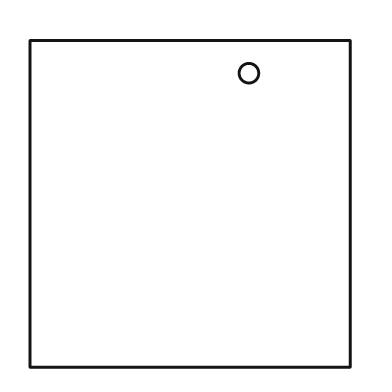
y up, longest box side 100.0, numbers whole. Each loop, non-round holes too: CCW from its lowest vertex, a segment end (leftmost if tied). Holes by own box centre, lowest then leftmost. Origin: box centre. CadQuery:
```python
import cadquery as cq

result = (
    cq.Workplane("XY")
    .moveTo(-49.0, -50.0)
    .lineTo(49.0, -50.0)
    .lineTo(49.0, 50.0)
    .lineTo(-49.0, 50.0)
    .close()
    .moveTo(18.0, 40.0)
    .circle(3.0)
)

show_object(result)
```